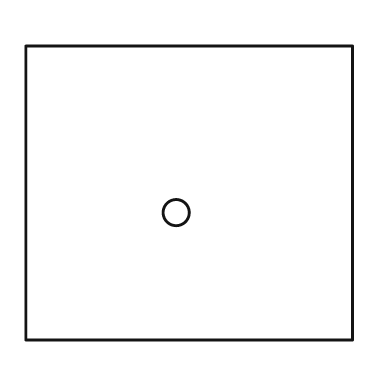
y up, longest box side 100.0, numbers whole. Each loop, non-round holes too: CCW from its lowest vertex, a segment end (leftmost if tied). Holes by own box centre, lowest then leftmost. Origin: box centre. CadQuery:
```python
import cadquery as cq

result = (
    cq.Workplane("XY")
    .moveTo(-50.0, -45.0)
    .lineTo(50.0, -45.0)
    .lineTo(50.0, 45.0)
    .lineTo(-50.0, 45.0)
    .close()
    .moveTo(-4.0, -6.0)
    .circle(4.0)
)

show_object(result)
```